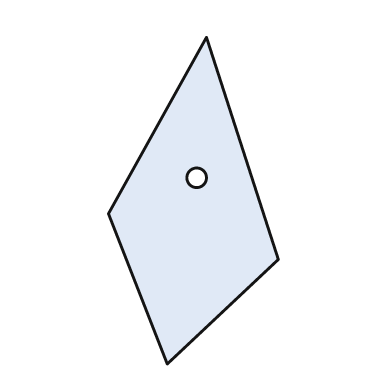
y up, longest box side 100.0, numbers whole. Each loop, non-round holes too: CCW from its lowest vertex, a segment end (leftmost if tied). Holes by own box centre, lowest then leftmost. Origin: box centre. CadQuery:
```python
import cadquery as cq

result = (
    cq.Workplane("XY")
    .moveTo(-8.0, -50.0)
    .lineTo(26.0, -18.0)
    .lineTo(4.0, 50.0)
    .lineTo(-26.0, -4.0)
    .close()
    .moveTo(1.0, 7.0)
    .circle(3.0)
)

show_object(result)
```